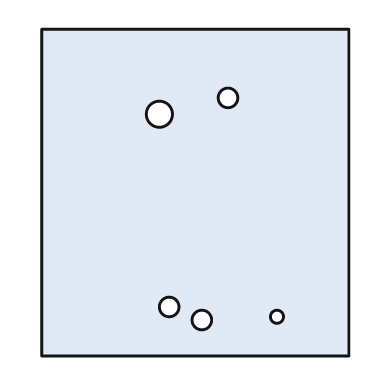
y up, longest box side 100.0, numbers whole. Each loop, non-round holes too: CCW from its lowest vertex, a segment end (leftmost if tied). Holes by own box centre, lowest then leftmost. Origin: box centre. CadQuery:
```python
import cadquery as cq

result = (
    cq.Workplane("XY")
    .moveTo(-47.0, -50.0)
    .lineTo(47.0, -50.0)
    .lineTo(47.0, 50.0)
    .lineTo(-47.0, 50.0)
    .close()
    .moveTo(2.0, -39.0)
    .circle(3.0)
    .moveTo(25.0, -38.0)
    .circle(2.0)
    .moveTo(-8.0, -35.0)
    .circle(3.0)
    .moveTo(-11.0, 24.0)
    .circle(4.0)
    .moveTo(10.0, 29.0)
    .circle(3.0)
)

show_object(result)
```